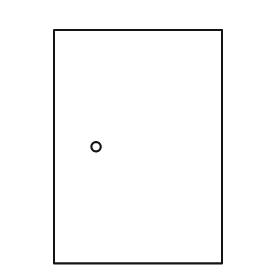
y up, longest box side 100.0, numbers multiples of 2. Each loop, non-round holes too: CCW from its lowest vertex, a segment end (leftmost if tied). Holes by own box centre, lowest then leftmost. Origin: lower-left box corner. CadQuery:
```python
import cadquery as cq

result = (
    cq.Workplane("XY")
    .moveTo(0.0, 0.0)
    .lineTo(72.0, 0.0)
    .lineTo(72.0, 100.0)
    .lineTo(0.0, 100.0)
    .close()
    .moveTo(18.0, 50.0)
    .circle(2.0)
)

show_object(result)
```